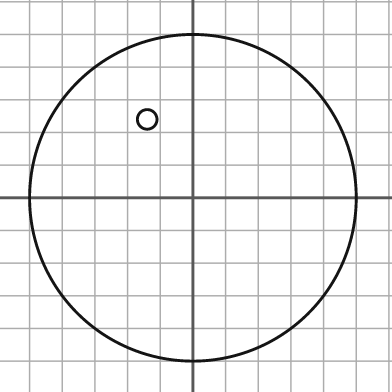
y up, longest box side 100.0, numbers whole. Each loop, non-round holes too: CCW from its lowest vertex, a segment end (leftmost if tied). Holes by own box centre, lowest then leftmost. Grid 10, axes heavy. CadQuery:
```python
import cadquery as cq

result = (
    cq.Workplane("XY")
    .moveTo(0.0, 0.0)
    .circle(50.0)
    .moveTo(-14.0, 24.0)
    .circle(3.0)
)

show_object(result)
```